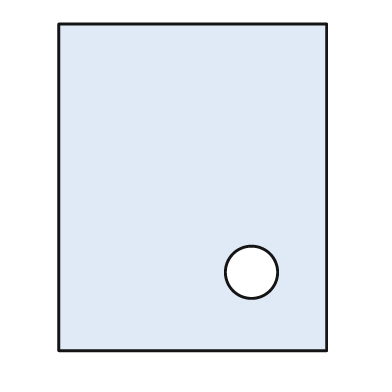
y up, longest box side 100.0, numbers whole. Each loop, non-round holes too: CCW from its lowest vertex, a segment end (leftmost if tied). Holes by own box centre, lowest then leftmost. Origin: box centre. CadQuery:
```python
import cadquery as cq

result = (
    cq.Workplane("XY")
    .moveTo(-41.0, -50.0)
    .lineTo(41.0, -50.0)
    .lineTo(41.0, 50.0)
    .lineTo(-41.0, 50.0)
    .close()
    .moveTo(18.0, -26.0)
    .circle(8.0)
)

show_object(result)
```